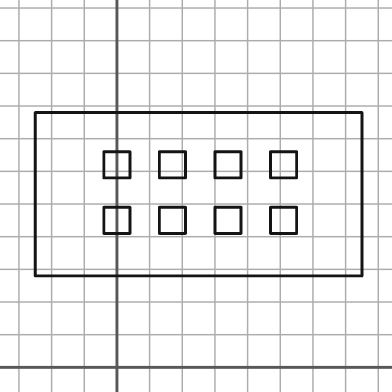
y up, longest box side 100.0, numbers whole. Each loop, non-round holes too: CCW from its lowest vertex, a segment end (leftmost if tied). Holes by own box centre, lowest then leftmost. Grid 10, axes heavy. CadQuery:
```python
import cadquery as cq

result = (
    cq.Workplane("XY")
    .moveTo(-25.0, 28.0)
    .lineTo(75.0, 28.0)
    .lineTo(75.0, 78.0)
    .lineTo(-25.0, 78.0)
    .close()
    .moveTo(-4.0, 41.0)
    .lineTo(4.0, 41.0)
    .lineTo(4.0, 49.0)
    .lineTo(-4.0, 49.0)
    .close()
    .moveTo(13.0, 41.0)
    .lineTo(21.0, 41.0)
    .lineTo(21.0, 49.0)
    .lineTo(13.0, 49.0)
    .close()
    .moveTo(30.0, 41.0)
    .lineTo(38.0, 41.0)
    .lineTo(38.0, 49.0)
    .lineTo(30.0, 49.0)
    .close()
    .moveTo(47.0, 41.0)
    .lineTo(55.0, 41.0)
    .lineTo(55.0, 49.0)
    .lineTo(47.0, 49.0)
    .close()
    .moveTo(-4.0, 58.0)
    .lineTo(4.0, 58.0)
    .lineTo(4.0, 66.0)
    .lineTo(-4.0, 66.0)
    .close()
    .moveTo(13.0, 58.0)
    .lineTo(21.0, 58.0)
    .lineTo(21.0, 66.0)
    .lineTo(13.0, 66.0)
    .close()
    .moveTo(30.0, 58.0)
    .lineTo(38.0, 58.0)
    .lineTo(38.0, 66.0)
    .lineTo(30.0, 66.0)
    .close()
    .moveTo(47.0, 58.0)
    .lineTo(55.0, 58.0)
    .lineTo(55.0, 66.0)
    .lineTo(47.0, 66.0)
    .close()
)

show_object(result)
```